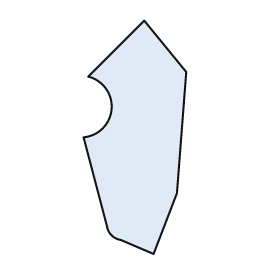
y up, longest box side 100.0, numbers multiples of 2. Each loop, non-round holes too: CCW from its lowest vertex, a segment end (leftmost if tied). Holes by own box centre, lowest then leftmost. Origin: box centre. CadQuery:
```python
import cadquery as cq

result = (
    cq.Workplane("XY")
    .moveTo(8.0, -50.0)
    .lineTo(18.0, -24.0)
    .lineTo(22.0, 28.0)
    .lineTo(4.0, 50.0)
    .lineTo(-20.0, 26.0)
    .threePointArc((-10.0, 12.0), (-22.0, 0.0))
    .lineTo(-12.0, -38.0)
    .threePointArc((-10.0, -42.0), (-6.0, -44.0))
    .close()
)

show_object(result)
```